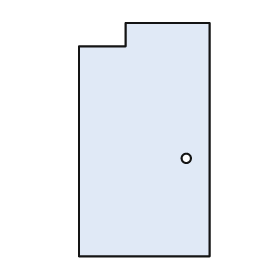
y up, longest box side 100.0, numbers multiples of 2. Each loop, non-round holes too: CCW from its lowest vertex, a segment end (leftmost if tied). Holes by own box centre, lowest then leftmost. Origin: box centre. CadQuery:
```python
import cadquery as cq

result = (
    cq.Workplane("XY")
    .moveTo(-28.0, -50.0)
    .lineTo(28.0, -50.0)
    .lineTo(28.0, 50.0)
    .lineTo(-8.0, 50.0)
    .lineTo(-8.0, 40.0)
    .lineTo(-28.0, 40.0)
    .close()
    .moveTo(18.0, -8.0)
    .circle(2.0)
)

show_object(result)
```